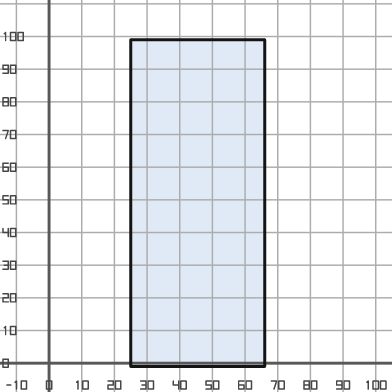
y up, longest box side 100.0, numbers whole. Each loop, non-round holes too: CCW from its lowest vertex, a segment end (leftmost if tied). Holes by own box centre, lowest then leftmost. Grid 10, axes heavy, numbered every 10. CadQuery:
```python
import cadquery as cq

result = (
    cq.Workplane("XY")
    .moveTo(25.0, -1.0)
    .lineTo(66.0, -1.0)
    .lineTo(66.0, 99.0)
    .lineTo(25.0, 99.0)
    .close()
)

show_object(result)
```